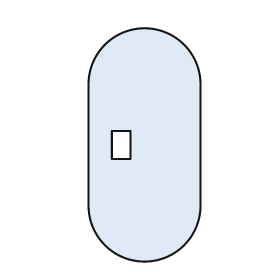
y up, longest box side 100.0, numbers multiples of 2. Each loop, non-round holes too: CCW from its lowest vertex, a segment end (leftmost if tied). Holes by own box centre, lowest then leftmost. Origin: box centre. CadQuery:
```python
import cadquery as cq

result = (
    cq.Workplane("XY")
    .moveTo(-24.0, -26.0)
    .threePointArc((0.0, -50.0), (24.0, -26.0))
    .lineTo(24.0, 26.0)
    .threePointArc((0.0, 50.0), (-24.0, 26.0))
    .close()
    .moveTo(-14.0, -6.0)
    .lineTo(-6.0, -6.0)
    .lineTo(-6.0, 6.0)
    .lineTo(-14.0, 6.0)
    .close()
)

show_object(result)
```